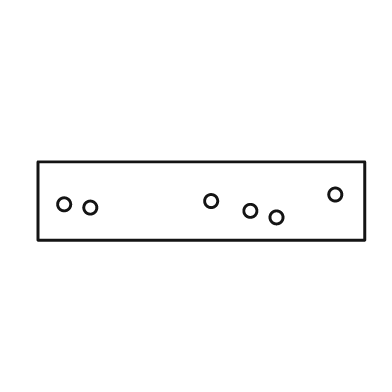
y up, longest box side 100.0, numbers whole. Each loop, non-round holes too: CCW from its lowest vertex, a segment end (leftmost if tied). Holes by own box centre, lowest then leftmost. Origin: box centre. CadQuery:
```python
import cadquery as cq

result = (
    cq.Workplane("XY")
    .moveTo(-50.0, -12.0)
    .lineTo(50.0, -12.0)
    .lineTo(50.0, 12.0)
    .lineTo(-50.0, 12.0)
    .close()
    .moveTo(23.0, -5.0)
    .circle(2.0)
    .moveTo(15.0, -3.0)
    .circle(2.0)
    .moveTo(-34.0, -2.0)
    .circle(2.0)
    .moveTo(-42.0, -1.0)
    .circle(2.0)
    .moveTo(3.0, 0.0)
    .circle(2.0)
    .moveTo(41.0, 2.0)
    .circle(2.0)
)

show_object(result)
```